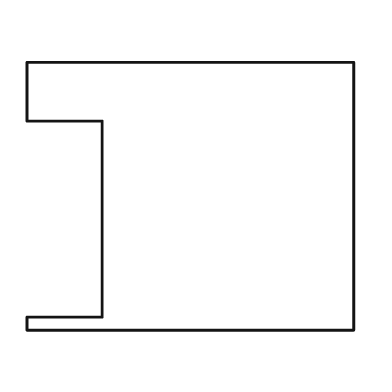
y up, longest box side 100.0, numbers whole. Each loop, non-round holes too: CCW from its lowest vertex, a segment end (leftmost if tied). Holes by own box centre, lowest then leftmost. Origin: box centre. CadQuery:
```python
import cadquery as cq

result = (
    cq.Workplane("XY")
    .moveTo(-50.0, -41.0)
    .lineTo(50.0, -41.0)
    .lineTo(50.0, 41.0)
    .lineTo(-50.0, 41.0)
    .lineTo(-50.0, 23.0)
    .lineTo(-27.0, 23.0)
    .lineTo(-27.0, -37.0)
    .lineTo(-50.0, -37.0)
    .close()
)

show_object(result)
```